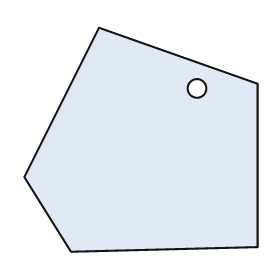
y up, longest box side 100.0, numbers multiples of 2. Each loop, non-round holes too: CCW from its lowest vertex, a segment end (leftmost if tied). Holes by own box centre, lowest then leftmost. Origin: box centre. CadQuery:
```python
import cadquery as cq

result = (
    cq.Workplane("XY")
    .moveTo(-30.0, -48.0)
    .lineTo(50.0, -46.0)
    .lineTo(50.0, 24.0)
    .lineTo(-18.0, 48.0)
    .lineTo(-50.0, -16.0)
    .close()
    .moveTo(24.0, 22.0)
    .circle(4.0)
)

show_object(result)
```